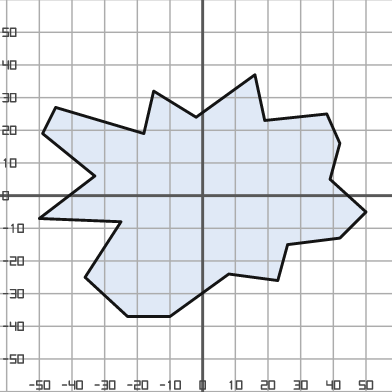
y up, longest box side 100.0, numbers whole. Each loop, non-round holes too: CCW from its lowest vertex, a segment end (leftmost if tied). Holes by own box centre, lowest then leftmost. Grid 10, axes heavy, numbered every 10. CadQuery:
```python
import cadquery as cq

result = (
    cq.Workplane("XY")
    .moveTo(-23.0, -37.0)
    .lineTo(-10.0, -37.0)
    .lineTo(8.0, -24.0)
    .lineTo(23.0, -26.0)
    .lineTo(26.0, -15.0)
    .lineTo(42.0, -13.0)
    .lineTo(50.0, -5.0)
    .lineTo(39.0, 5.0)
    .lineTo(42.0, 16.0)
    .lineTo(38.0, 25.0)
    .lineTo(19.0, 23.0)
    .lineTo(16.0, 37.0)
    .lineTo(-2.0, 24.0)
    .lineTo(-15.0, 32.0)
    .lineTo(-18.0, 19.0)
    .lineTo(-45.0, 27.0)
    .lineTo(-49.0, 19.0)
    .lineTo(-33.0, 6.0)
    .lineTo(-50.0, -7.0)
    .lineTo(-25.0, -8.0)
    .lineTo(-36.0, -25.0)
    .close()
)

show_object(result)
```